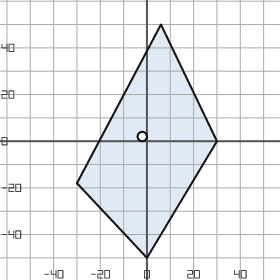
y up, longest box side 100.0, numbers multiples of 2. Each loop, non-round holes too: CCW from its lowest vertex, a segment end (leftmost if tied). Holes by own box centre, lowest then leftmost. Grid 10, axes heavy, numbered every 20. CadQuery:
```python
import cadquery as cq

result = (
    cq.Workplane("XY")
    .moveTo(0.0, -50.0)
    .lineTo(30.0, 0.0)
    .lineTo(6.0, 50.0)
    .lineTo(-30.0, -18.0)
    .close()
    .moveTo(-2.0, 2.0)
    .circle(2.0)
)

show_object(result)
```